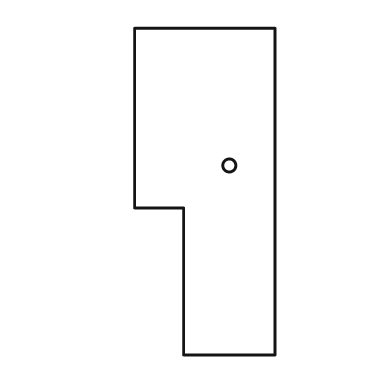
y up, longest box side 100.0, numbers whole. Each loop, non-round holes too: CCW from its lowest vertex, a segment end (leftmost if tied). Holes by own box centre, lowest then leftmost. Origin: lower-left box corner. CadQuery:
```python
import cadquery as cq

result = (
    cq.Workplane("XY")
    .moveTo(15.0, 0.0)
    .lineTo(43.0, 0.0)
    .lineTo(43.0, 100.0)
    .lineTo(0.0, 100.0)
    .lineTo(0.0, 45.0)
    .lineTo(15.0, 45.0)
    .close()
    .moveTo(29.0, 58.0)
    .circle(2.0)
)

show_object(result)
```